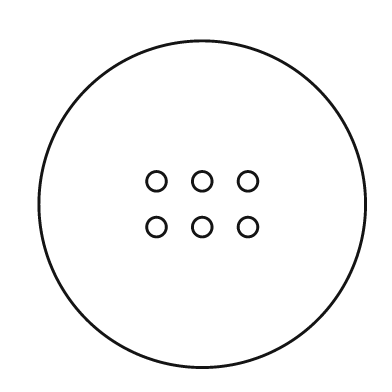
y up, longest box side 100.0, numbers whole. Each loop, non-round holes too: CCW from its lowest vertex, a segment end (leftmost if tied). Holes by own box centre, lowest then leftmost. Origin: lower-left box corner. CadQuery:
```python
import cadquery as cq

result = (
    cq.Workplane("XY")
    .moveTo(50.0, 50.0)
    .circle(50.0)
    .moveTo(36.0, 43.0)
    .circle(3.0)
    .moveTo(50.0, 43.0)
    .circle(3.0)
    .moveTo(64.0, 43.0)
    .circle(3.0)
    .moveTo(36.0, 57.0)
    .circle(3.0)
    .moveTo(50.0, 57.0)
    .circle(3.0)
    .moveTo(64.0, 57.0)
    .circle(3.0)
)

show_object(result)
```